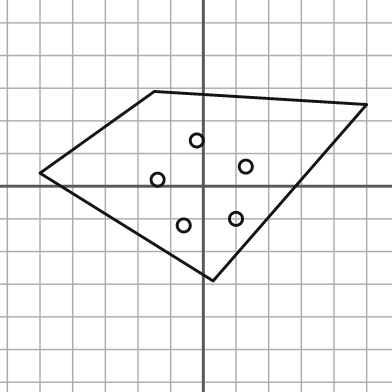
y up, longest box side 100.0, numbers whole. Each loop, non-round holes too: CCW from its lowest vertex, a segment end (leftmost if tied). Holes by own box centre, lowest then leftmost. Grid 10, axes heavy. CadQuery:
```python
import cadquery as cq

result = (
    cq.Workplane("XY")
    .moveTo(3.0, -29.0)
    .lineTo(50.0, 25.0)
    .lineTo(-15.0, 29.0)
    .lineTo(-50.0, 4.0)
    .close()
    .moveTo(-6.0, -12.0)
    .circle(2.0)
    .moveTo(10.0, -10.0)
    .circle(2.0)
    .moveTo(-14.0, 2.0)
    .circle(2.0)
    .moveTo(13.0, 6.0)
    .circle(2.0)
    .moveTo(-2.0, 14.0)
    .circle(2.0)
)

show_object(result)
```